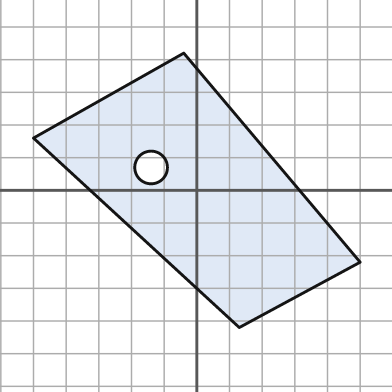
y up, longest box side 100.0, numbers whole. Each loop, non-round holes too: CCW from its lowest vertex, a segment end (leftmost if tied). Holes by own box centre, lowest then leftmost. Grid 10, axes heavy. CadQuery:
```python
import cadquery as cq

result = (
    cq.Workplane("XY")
    .moveTo(13.0, -42.0)
    .lineTo(50.0, -22.0)
    .lineTo(-4.0, 42.0)
    .lineTo(-50.0, 16.0)
    .close()
    .moveTo(-14.0, 7.0)
    .circle(5.0)
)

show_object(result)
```